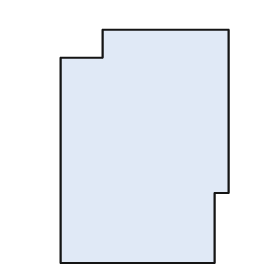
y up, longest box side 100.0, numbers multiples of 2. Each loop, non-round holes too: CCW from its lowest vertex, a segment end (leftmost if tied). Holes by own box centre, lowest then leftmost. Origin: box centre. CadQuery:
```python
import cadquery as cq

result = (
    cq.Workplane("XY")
    .moveTo(-36.0, -50.0)
    .lineTo(30.0, -50.0)
    .lineTo(30.0, -20.0)
    .lineTo(36.0, -20.0)
    .lineTo(36.0, 50.0)
    .lineTo(-18.0, 50.0)
    .lineTo(-18.0, 38.0)
    .lineTo(-36.0, 38.0)
    .close()
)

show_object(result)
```